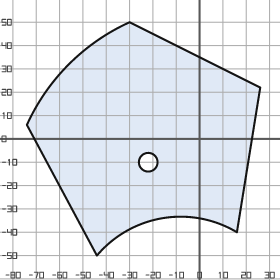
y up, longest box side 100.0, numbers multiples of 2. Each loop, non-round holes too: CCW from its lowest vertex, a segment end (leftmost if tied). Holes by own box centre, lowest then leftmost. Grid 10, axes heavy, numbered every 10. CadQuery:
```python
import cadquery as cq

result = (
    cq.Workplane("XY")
    .moveTo(-44.0, -50.0)
    .threePointArc((-16.0, -34.0), (16.0, -40.0))
    .lineTo(26.0, 22.0)
    .lineTo(-30.0, 50.0)
    .threePointArc((-56.0, 32.0), (-74.0, 6.0))
    .close()
    .moveTo(-22.0, -10.0)
    .circle(4.0)
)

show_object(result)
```